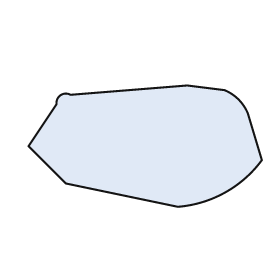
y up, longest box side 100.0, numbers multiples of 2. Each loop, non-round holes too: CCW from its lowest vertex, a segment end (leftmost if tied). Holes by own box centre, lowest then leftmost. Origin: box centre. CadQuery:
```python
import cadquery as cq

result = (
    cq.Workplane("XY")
    .moveTo(14.0, -26.0)
    .threePointArc((34.0, -20.0), (50.0, -6.0))
    .lineTo(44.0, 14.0)
    .threePointArc((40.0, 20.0), (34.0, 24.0))
    .lineTo(18.0, 26.0)
    .lineTo(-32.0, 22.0)
    .threePointArc((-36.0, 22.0), (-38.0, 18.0))
    .lineTo(-50.0, 0.0)
    .lineTo(-34.0, -16.0)
    .close()
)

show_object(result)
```